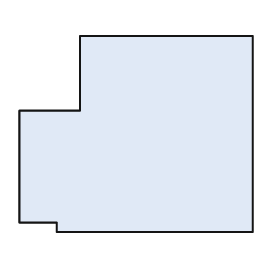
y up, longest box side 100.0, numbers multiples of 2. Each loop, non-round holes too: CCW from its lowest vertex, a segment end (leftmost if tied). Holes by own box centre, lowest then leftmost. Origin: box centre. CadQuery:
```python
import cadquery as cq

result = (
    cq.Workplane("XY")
    .moveTo(-34.0, -42.0)
    .lineTo(50.0, -42.0)
    .lineTo(50.0, 42.0)
    .lineTo(-24.0, 42.0)
    .lineTo(-24.0, 10.0)
    .lineTo(-50.0, 10.0)
    .lineTo(-50.0, -38.0)
    .lineTo(-34.0, -38.0)
    .close()
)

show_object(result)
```